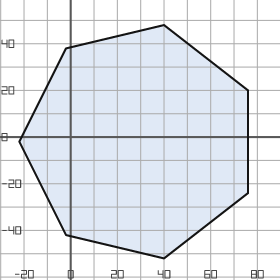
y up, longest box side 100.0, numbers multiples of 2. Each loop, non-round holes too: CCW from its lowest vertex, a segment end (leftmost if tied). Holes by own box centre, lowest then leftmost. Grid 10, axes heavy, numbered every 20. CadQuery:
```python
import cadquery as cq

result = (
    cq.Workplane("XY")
    .moveTo(40.0, -52.0)
    .lineTo(76.0, -24.0)
    .lineTo(76.0, 20.0)
    .lineTo(40.0, 48.0)
    .lineTo(-2.0, 38.0)
    .lineTo(-22.0, -2.0)
    .lineTo(-2.0, -42.0)
    .close()
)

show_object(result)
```